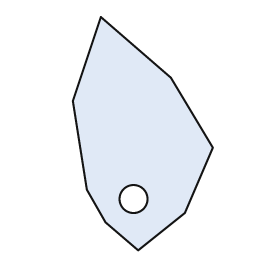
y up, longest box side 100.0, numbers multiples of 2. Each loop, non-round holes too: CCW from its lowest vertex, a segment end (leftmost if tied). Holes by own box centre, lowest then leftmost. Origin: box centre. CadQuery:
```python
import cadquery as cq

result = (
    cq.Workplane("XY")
    .moveTo(-2.0, -50.0)
    .lineTo(18.0, -34.0)
    .lineTo(30.0, -6.0)
    .lineTo(12.0, 24.0)
    .lineTo(-18.0, 50.0)
    .lineTo(-30.0, 14.0)
    .lineTo(-24.0, -24.0)
    .lineTo(-16.0, -38.0)
    .close()
    .moveTo(-4.0, -28.0)
    .circle(6.0)
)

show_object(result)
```